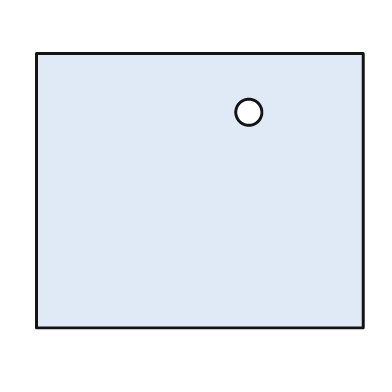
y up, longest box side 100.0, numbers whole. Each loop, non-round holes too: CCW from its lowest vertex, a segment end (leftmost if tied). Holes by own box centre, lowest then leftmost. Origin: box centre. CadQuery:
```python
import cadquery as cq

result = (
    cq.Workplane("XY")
    .moveTo(-50.0, -42.0)
    .lineTo(50.0, -42.0)
    .lineTo(50.0, 42.0)
    .lineTo(-50.0, 42.0)
    .close()
    .moveTo(15.0, 24.0)
    .circle(4.0)
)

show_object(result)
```